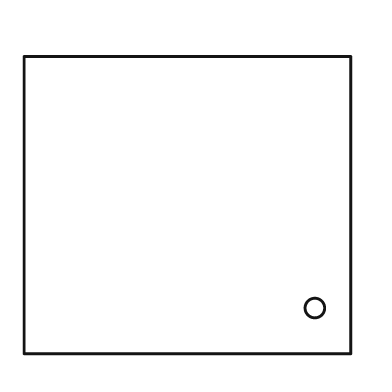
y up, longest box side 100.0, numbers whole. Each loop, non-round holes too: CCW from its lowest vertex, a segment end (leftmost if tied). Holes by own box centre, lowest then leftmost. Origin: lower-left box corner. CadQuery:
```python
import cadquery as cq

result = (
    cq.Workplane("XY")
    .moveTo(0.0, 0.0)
    .lineTo(100.0, 0.0)
    .lineTo(100.0, 91.0)
    .lineTo(0.0, 91.0)
    .close()
    .moveTo(89.0, 14.0)
    .circle(3.0)
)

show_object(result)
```